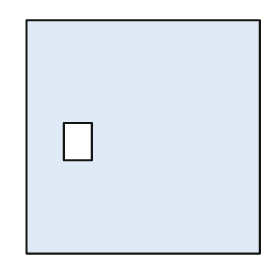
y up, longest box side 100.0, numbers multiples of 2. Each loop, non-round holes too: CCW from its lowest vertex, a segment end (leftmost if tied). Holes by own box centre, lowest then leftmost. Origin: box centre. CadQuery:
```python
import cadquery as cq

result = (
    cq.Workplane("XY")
    .moveTo(-50.0, -50.0)
    .lineTo(50.0, -50.0)
    .lineTo(50.0, 50.0)
    .lineTo(-50.0, 50.0)
    .close()
    .moveTo(-34.0, -10.0)
    .lineTo(-22.0, -10.0)
    .lineTo(-22.0, 6.0)
    .lineTo(-34.0, 6.0)
    .close()
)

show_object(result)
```